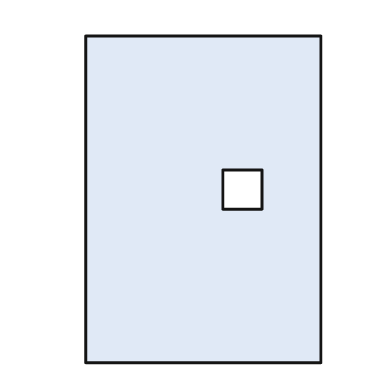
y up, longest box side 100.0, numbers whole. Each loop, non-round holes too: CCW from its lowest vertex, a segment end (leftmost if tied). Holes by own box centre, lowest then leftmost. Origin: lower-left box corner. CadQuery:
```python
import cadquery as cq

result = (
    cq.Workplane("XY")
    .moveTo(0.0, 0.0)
    .lineTo(72.0, 0.0)
    .lineTo(72.0, 100.0)
    .lineTo(0.0, 100.0)
    .close()
    .moveTo(42.0, 47.0)
    .lineTo(54.0, 47.0)
    .lineTo(54.0, 59.0)
    .lineTo(42.0, 59.0)
    .close()
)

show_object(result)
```